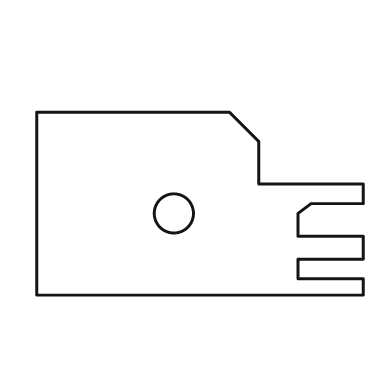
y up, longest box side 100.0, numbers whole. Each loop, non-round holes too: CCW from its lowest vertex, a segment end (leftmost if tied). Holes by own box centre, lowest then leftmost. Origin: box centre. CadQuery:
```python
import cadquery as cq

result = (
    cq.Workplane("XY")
    .moveTo(-50.0, -28.0)
    .lineTo(50.0, -28.0)
    .lineTo(50.0, -23.0)
    .lineTo(30.0, -23.0)
    .lineTo(30.0, -17.0)
    .lineTo(50.0, -17.0)
    .lineTo(50.0, -10.0)
    .lineTo(30.0, -10.0)
    .lineTo(30.0, -3.0)
    .lineTo(34.0, 0.0)
    .lineTo(50.0, 0.0)
    .lineTo(50.0, 6.0)
    .lineTo(18.0, 6.0)
    .lineTo(18.0, 19.0)
    .lineTo(9.0, 28.0)
    .lineTo(-50.0, 28.0)
    .close()
    .moveTo(-8.0, -3.0)
    .circle(6.0)
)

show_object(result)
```